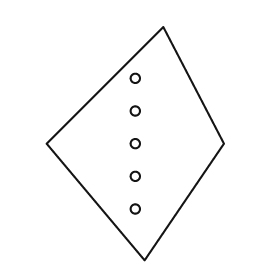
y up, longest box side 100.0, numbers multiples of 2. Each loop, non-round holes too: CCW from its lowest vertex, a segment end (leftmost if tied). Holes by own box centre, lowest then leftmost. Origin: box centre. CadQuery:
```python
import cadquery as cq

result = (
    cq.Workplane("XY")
    .moveTo(4.0, -50.0)
    .lineTo(38.0, 0.0)
    .lineTo(12.0, 50.0)
    .lineTo(-38.0, 0.0)
    .close()
    .moveTo(0.0, -28.0)
    .circle(2.0)
    .moveTo(0.0, -14.0)
    .circle(2.0)
    .moveTo(0.0, 0.0)
    .circle(2.0)
    .moveTo(0.0, 14.0)
    .circle(2.0)
    .moveTo(0.0, 28.0)
    .circle(2.0)
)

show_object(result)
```